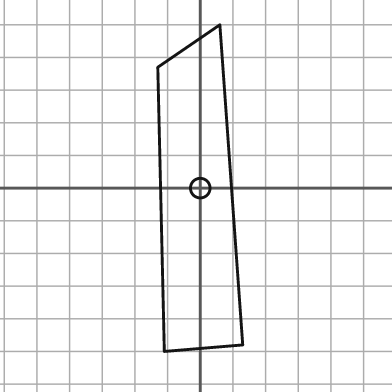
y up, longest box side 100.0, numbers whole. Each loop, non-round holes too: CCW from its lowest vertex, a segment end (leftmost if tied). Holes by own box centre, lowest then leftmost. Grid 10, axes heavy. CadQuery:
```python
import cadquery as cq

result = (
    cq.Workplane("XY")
    .moveTo(-11.0, -50.0)
    .lineTo(13.0, -48.0)
    .lineTo(6.0, 50.0)
    .lineTo(-13.0, 37.0)
    .close()
    .moveTo(0.0, 0.0)
    .circle(3.0)
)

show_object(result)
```